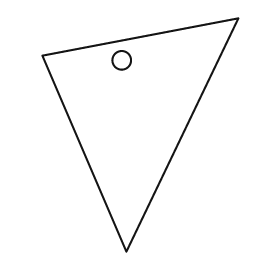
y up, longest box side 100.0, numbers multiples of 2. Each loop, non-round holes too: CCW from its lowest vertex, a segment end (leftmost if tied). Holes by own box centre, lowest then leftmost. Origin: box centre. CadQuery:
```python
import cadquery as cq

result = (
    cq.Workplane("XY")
    .moveTo(-6.0, -50.0)
    .lineTo(42.0, 50.0)
    .lineTo(-42.0, 34.0)
    .close()
    .moveTo(-8.0, 32.0)
    .circle(4.0)
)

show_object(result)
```